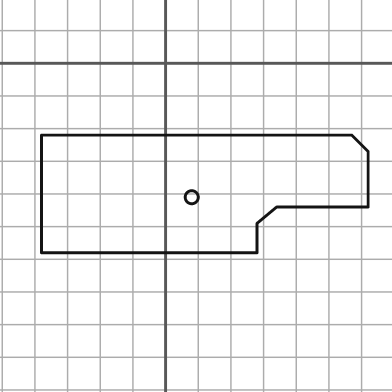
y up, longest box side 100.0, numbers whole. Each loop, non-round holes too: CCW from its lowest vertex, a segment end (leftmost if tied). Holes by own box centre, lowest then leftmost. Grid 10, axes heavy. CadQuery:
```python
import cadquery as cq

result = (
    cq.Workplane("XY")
    .moveTo(-38.0, -58.0)
    .lineTo(28.0, -58.0)
    .lineTo(28.0, -49.0)
    .lineTo(34.0, -44.0)
    .lineTo(62.0, -44.0)
    .lineTo(62.0, -27.0)
    .lineTo(57.0, -22.0)
    .lineTo(-38.0, -22.0)
    .close()
    .moveTo(8.0, -41.0)
    .circle(2.0)
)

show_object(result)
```